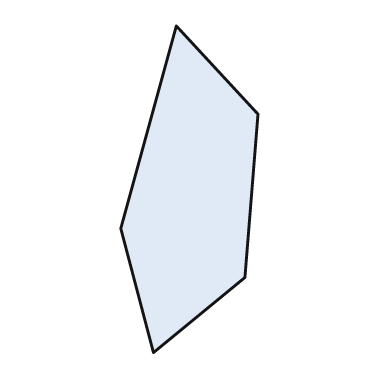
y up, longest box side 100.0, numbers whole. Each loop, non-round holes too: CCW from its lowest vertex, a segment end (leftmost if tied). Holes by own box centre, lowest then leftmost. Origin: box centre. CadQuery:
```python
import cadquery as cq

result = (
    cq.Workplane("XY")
    .moveTo(-11.0, -50.0)
    .lineTo(17.0, -27.0)
    .lineTo(21.0, 23.0)
    .lineTo(-4.0, 50.0)
    .lineTo(-21.0, -12.0)
    .close()
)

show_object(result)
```